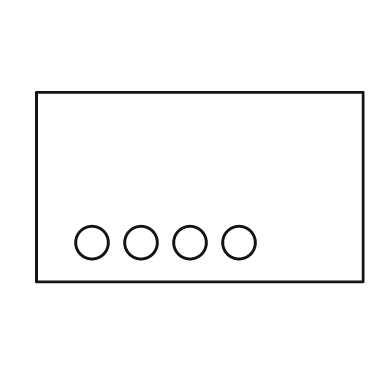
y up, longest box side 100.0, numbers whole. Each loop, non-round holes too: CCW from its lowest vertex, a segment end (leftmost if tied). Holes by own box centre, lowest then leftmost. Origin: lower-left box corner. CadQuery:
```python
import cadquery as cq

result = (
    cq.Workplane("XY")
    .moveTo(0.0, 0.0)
    .lineTo(100.0, 0.0)
    .lineTo(100.0, 58.0)
    .lineTo(0.0, 58.0)
    .close()
    .moveTo(17.0, 12.0)
    .circle(5.0)
    .moveTo(32.0, 12.0)
    .circle(5.0)
    .moveTo(47.0, 12.0)
    .circle(5.0)
    .moveTo(62.0, 12.0)
    .circle(5.0)
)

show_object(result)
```